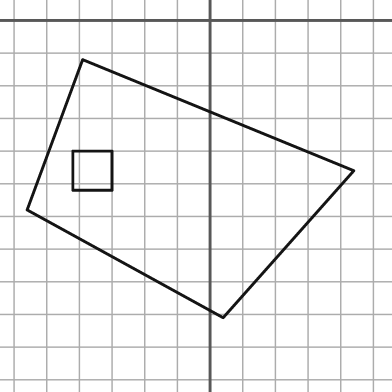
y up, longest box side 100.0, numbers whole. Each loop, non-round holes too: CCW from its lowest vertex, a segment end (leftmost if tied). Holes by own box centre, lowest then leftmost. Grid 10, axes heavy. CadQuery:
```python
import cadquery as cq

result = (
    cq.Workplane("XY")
    .moveTo(4.0, -91.0)
    .lineTo(44.0, -46.0)
    .lineTo(-39.0, -12.0)
    .lineTo(-56.0, -58.0)
    .close()
    .moveTo(-42.0, -52.0)
    .lineTo(-30.0, -52.0)
    .lineTo(-30.0, -40.0)
    .lineTo(-42.0, -40.0)
    .close()
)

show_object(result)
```